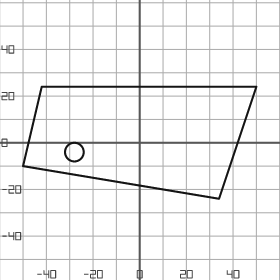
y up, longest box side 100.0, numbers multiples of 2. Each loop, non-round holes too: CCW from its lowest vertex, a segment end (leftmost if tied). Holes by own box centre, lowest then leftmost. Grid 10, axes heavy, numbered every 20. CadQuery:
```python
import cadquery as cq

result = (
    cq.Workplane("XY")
    .moveTo(34.0, -24.0)
    .lineTo(50.0, 24.0)
    .lineTo(-42.0, 24.0)
    .lineTo(-50.0, -10.0)
    .close()
    .moveTo(-28.0, -4.0)
    .circle(4.0)
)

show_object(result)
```